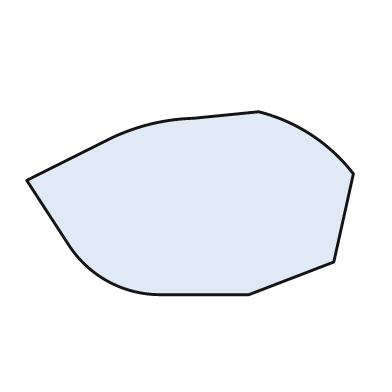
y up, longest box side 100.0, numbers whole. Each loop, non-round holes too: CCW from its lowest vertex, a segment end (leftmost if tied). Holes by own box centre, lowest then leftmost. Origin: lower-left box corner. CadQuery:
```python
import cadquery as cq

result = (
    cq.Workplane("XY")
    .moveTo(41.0, 0.0)
    .lineTo(68.0, 0.0)
    .lineTo(94.0, 10.0)
    .lineTo(100.0, 37.0)
    .threePointArc((87.0, 49.0), (71.0, 56.0))
    .lineTo(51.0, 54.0)
    .threePointArc((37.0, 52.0), (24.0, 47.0))
    .lineTo(0.0, 35.0)
    .lineTo(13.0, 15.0)
    .threePointArc((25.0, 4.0), (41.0, 0.0))
    .close()
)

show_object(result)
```